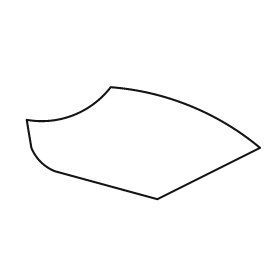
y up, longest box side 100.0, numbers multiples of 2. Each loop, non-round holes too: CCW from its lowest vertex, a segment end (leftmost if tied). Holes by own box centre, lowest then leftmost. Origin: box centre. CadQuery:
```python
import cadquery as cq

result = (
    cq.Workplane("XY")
    .moveTo(6.0, -24.0)
    .lineTo(50.0, -2.0)
    .threePointArc((20.0, 16.0), (-14.0, 24.0))
    .threePointArc((-30.0, 12.0), (-50.0, 10.0))
    .lineTo(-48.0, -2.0)
    .threePointArc((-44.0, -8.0), (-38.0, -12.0))
    .close()
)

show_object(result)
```